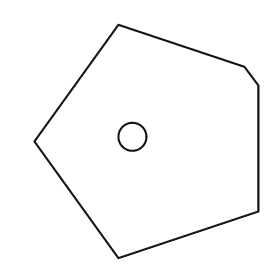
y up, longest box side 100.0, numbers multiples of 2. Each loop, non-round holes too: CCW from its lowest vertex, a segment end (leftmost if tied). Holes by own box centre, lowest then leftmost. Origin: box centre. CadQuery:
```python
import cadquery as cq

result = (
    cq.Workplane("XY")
    .moveTo(-12.0, -50.0)
    .lineTo(48.0, -30.0)
    .lineTo(48.0, 24.0)
    .lineTo(42.0, 32.0)
    .lineTo(-12.0, 50.0)
    .lineTo(-48.0, 0.0)
    .close()
    .moveTo(-6.0, 2.0)
    .circle(6.0)
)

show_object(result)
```